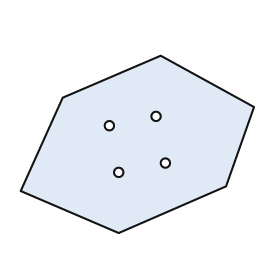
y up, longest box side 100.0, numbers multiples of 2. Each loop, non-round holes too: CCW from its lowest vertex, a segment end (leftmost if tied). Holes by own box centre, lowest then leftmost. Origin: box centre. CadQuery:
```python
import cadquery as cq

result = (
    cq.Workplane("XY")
    .moveTo(-8.0, -38.0)
    .lineTo(38.0, -18.0)
    .lineTo(50.0, 16.0)
    .lineTo(10.0, 38.0)
    .lineTo(-32.0, 20.0)
    .lineTo(-50.0, -20.0)
    .close()
    .moveTo(-8.0, -12.0)
    .circle(2.0)
    .moveTo(12.0, -8.0)
    .circle(2.0)
    .moveTo(-12.0, 8.0)
    .circle(2.0)
    .moveTo(8.0, 12.0)
    .circle(2.0)
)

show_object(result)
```